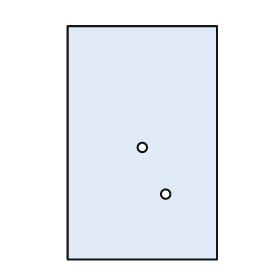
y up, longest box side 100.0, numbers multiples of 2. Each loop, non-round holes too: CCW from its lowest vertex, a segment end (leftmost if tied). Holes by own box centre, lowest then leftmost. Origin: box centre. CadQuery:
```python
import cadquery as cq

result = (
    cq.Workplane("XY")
    .moveTo(-32.0, -50.0)
    .lineTo(32.0, -50.0)
    .lineTo(32.0, 50.0)
    .lineTo(-32.0, 50.0)
    .close()
    .moveTo(10.0, -22.0)
    .circle(2.0)
    .moveTo(0.0, -2.0)
    .circle(2.0)
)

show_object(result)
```